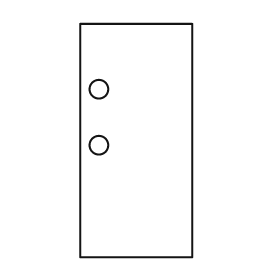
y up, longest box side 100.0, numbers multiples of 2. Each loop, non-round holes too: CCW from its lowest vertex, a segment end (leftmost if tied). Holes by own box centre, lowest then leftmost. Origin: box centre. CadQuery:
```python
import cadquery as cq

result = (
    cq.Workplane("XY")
    .moveTo(-24.0, -50.0)
    .lineTo(24.0, -50.0)
    .lineTo(24.0, 50.0)
    .lineTo(-24.0, 50.0)
    .close()
    .moveTo(-16.0, -2.0)
    .circle(4.0)
    .moveTo(-16.0, 22.0)
    .circle(4.0)
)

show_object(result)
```